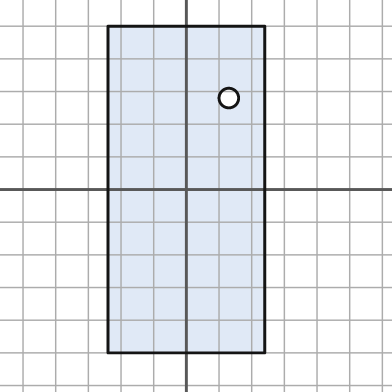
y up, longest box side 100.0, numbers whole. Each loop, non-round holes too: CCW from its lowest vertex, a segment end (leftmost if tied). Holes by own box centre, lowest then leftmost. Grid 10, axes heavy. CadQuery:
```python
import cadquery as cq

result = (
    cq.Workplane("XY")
    .moveTo(-24.0, -50.0)
    .lineTo(24.0, -50.0)
    .lineTo(24.0, 50.0)
    .lineTo(-24.0, 50.0)
    .close()
    .moveTo(13.0, 28.0)
    .circle(3.0)
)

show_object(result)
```